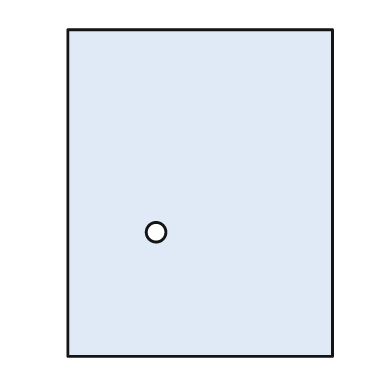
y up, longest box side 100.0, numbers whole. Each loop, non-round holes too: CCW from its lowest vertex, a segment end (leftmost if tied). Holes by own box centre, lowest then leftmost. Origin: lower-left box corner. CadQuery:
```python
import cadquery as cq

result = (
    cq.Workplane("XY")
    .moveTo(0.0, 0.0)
    .lineTo(81.0, 0.0)
    .lineTo(81.0, 100.0)
    .lineTo(0.0, 100.0)
    .close()
    .moveTo(27.0, 38.0)
    .circle(3.0)
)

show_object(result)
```